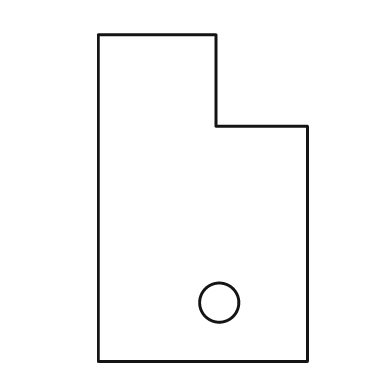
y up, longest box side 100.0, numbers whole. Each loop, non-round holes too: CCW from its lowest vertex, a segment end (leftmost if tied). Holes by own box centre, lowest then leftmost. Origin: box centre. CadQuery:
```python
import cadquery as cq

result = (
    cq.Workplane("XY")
    .moveTo(-32.0, -50.0)
    .lineTo(32.0, -50.0)
    .lineTo(32.0, 22.0)
    .lineTo(4.0, 22.0)
    .lineTo(4.0, 50.0)
    .lineTo(-32.0, 50.0)
    .close()
    .moveTo(5.0, -32.0)
    .circle(6.0)
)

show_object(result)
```